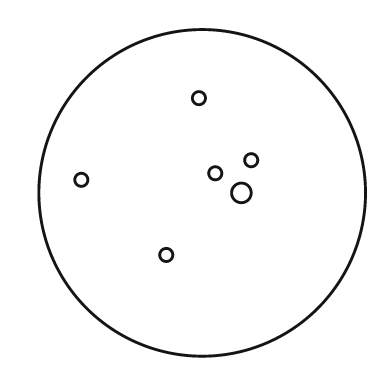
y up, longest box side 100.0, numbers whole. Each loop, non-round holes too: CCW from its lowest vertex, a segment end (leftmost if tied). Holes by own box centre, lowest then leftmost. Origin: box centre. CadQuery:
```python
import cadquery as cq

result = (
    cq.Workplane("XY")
    .moveTo(0.0, 0.0)
    .circle(50.0)
    .moveTo(-11.0, -19.0)
    .circle(2.0)
    .moveTo(12.0, 0.0)
    .circle(3.0)
    .moveTo(-37.0, 4.0)
    .circle(2.0)
    .moveTo(4.0, 6.0)
    .circle(2.0)
    .moveTo(15.0, 10.0)
    .circle(2.0)
    .moveTo(-1.0, 29.0)
    .circle(2.0)
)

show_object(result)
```